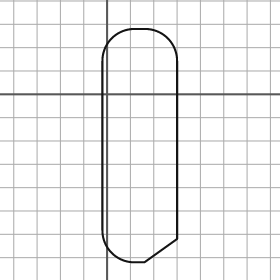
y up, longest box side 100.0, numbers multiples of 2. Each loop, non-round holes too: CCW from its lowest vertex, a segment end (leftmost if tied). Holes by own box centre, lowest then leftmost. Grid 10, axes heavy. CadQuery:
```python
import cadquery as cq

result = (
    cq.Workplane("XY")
    .moveTo(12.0, -72.0)
    .lineTo(16.0, -72.0)
    .lineTo(30.0, -62.0)
    .lineTo(30.0, 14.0)
    .threePointArc((26.0, 24.0), (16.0, 28.0))
    .lineTo(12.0, 28.0)
    .threePointArc((2.0, 24.0), (-2.0, 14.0))
    .lineTo(-2.0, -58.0)
    .threePointArc((2.0, -68.0), (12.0, -72.0))
    .close()
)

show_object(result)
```